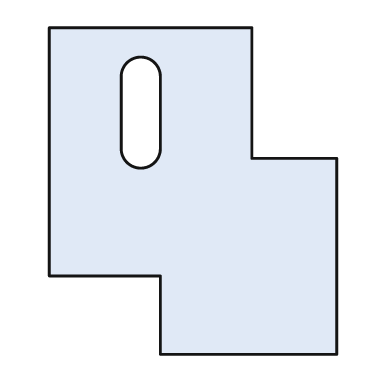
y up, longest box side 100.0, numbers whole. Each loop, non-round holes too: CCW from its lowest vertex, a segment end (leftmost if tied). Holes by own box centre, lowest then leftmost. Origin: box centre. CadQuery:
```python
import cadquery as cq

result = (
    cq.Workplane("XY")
    .moveTo(-10.0, -50.0)
    .lineTo(44.0, -50.0)
    .lineTo(44.0, 10.0)
    .lineTo(18.0, 10.0)
    .lineTo(18.0, 50.0)
    .lineTo(-44.0, 50.0)
    .lineTo(-44.0, -26.0)
    .lineTo(-10.0, -26.0)
    .close()
    .moveTo(-22.0, 13.0)
    .threePointArc((-16.0, 7.0), (-10.0, 13.0))
    .lineTo(-10.0, 35.0)
    .threePointArc((-16.0, 41.0), (-22.0, 35.0))
    .close()
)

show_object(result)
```